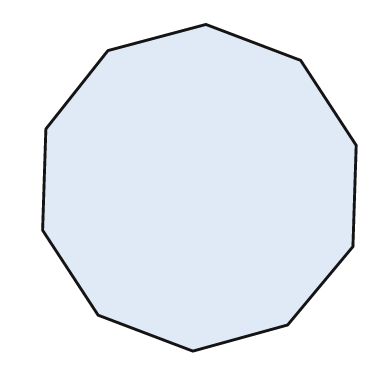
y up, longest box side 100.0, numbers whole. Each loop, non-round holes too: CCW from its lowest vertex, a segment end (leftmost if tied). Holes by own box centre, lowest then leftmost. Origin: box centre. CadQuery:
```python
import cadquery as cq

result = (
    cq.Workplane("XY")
    .moveTo(-2.0, -50.0)
    .lineTo(27.0, -42.0)
    .lineTo(47.0, -18.0)
    .lineTo(48.0, 13.0)
    .lineTo(31.0, 39.0)
    .lineTo(2.0, 50.0)
    .lineTo(-28.0, 42.0)
    .lineTo(-47.0, 18.0)
    .lineTo(-48.0, -13.0)
    .lineTo(-31.0, -39.0)
    .close()
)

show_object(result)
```